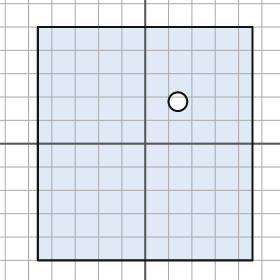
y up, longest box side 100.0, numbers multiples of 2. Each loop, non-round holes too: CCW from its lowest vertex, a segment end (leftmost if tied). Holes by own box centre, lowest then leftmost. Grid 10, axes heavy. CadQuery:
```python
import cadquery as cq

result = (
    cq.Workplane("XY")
    .moveTo(-46.0, -50.0)
    .lineTo(46.0, -50.0)
    .lineTo(46.0, 50.0)
    .lineTo(-46.0, 50.0)
    .close()
    .moveTo(14.0, 18.0)
    .circle(4.0)
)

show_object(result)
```